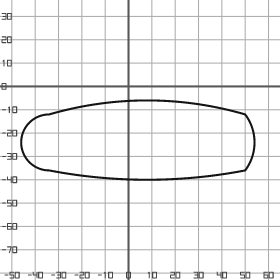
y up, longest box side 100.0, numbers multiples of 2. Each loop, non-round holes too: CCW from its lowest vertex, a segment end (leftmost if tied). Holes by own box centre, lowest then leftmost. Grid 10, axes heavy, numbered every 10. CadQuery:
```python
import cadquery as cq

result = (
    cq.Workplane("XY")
    .moveTo(-34.0, -36.0)
    .threePointArc((8.0, -40.0), (50.0, -36.0))
    .threePointArc((54.0, -24.0), (50.0, -12.0))
    .threePointArc((8.0, -6.0), (-34.0, -12.0))
    .threePointArc((-46.0, -24.0), (-34.0, -36.0))
    .close()
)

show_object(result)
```